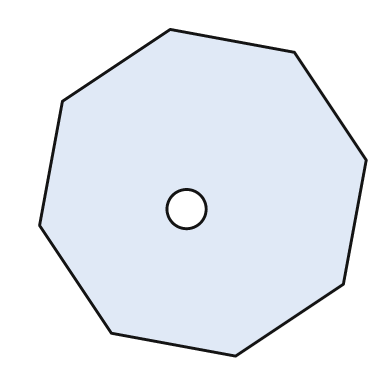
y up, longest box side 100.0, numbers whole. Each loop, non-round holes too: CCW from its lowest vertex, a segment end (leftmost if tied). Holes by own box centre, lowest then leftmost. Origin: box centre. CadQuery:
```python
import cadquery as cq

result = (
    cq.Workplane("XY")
    .moveTo(10.0, -50.0)
    .lineTo(43.0, -28.0)
    .lineTo(50.0, 10.0)
    .lineTo(28.0, 43.0)
    .lineTo(-10.0, 50.0)
    .lineTo(-43.0, 28.0)
    .lineTo(-50.0, -10.0)
    .lineTo(-28.0, -43.0)
    .close()
    .moveTo(-5.0, -5.0)
    .circle(6.0)
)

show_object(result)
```